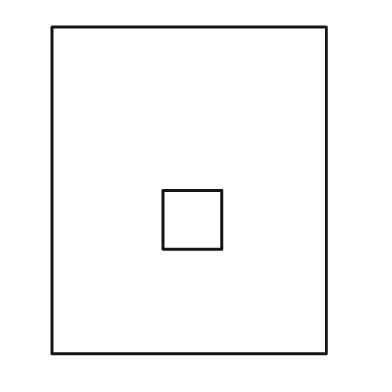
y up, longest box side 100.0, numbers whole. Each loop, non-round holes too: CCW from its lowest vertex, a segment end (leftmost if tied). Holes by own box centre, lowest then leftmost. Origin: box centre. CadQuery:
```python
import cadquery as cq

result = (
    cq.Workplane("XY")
    .moveTo(-42.0, -50.0)
    .lineTo(42.0, -50.0)
    .lineTo(42.0, 50.0)
    .lineTo(-42.0, 50.0)
    .close()
    .moveTo(-8.0, -18.0)
    .lineTo(10.0, -18.0)
    .lineTo(10.0, 0.0)
    .lineTo(-8.0, 0.0)
    .close()
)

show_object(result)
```